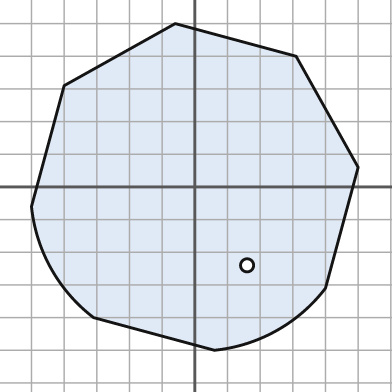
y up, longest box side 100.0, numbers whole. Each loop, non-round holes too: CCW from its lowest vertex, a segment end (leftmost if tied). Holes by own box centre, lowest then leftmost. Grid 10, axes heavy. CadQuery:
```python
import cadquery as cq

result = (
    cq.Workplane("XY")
    .moveTo(6.0, -50.0)
    .threePointArc((25.0, -44.0), (40.0, -31.0))
    .lineTo(50.0, 6.0)
    .lineTo(31.0, 40.0)
    .lineTo(-6.0, 50.0)
    .lineTo(-40.0, 31.0)
    .lineTo(-50.0, -6.0)
    .threePointArc((-44.0, -25.0), (-31.0, -40.0))
    .close()
    .moveTo(16.0, -24.0)
    .circle(2.0)
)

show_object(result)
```